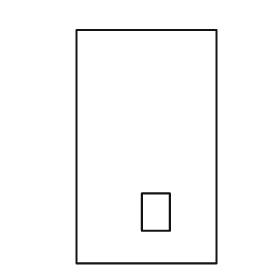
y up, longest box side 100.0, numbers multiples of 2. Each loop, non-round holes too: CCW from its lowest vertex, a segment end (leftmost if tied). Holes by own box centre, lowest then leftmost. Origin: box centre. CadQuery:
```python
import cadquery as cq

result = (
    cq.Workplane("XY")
    .moveTo(-30.0, -50.0)
    .lineTo(30.0, -50.0)
    .lineTo(30.0, 50.0)
    .lineTo(-30.0, 50.0)
    .close()
    .moveTo(-2.0, -36.0)
    .lineTo(10.0, -36.0)
    .lineTo(10.0, -20.0)
    .lineTo(-2.0, -20.0)
    .close()
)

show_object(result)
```